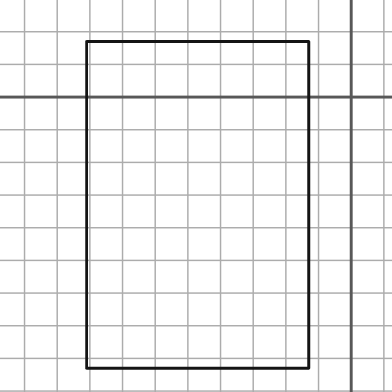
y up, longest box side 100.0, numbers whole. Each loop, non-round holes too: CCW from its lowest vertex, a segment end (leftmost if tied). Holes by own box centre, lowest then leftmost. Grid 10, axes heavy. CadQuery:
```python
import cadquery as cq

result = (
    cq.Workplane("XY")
    .moveTo(-81.0, -83.0)
    .lineTo(-13.0, -83.0)
    .lineTo(-13.0, 17.0)
    .lineTo(-81.0, 17.0)
    .close()
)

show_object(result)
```